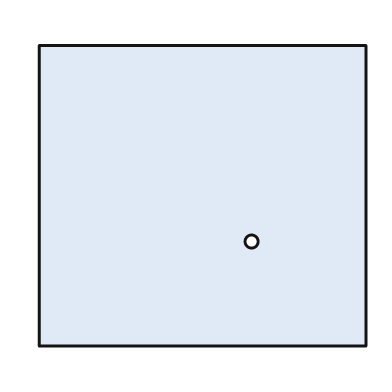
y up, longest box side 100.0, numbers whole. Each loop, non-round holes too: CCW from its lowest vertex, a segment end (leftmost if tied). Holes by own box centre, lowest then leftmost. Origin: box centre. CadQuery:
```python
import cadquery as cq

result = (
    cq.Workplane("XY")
    .moveTo(-50.0, -46.0)
    .lineTo(50.0, -46.0)
    .lineTo(50.0, 46.0)
    .lineTo(-50.0, 46.0)
    .close()
    .moveTo(15.0, -14.0)
    .circle(2.0)
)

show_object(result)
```